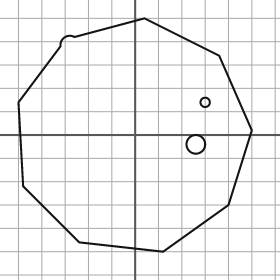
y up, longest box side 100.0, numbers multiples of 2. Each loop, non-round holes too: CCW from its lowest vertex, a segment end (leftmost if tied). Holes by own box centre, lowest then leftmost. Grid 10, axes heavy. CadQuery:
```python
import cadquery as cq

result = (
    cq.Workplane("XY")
    .moveTo(12.0, -50.0)
    .lineTo(40.0, -30.0)
    .lineTo(50.0, 2.0)
    .lineTo(36.0, 34.0)
    .lineTo(4.0, 50.0)
    .lineTo(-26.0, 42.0)
    .threePointArc((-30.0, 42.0), (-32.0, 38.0))
    .lineTo(-50.0, 14.0)
    .lineTo(-48.0, -22.0)
    .lineTo(-24.0, -46.0)
    .close()
    .moveTo(26.0, -4.0)
    .circle(4.0)
    .moveTo(30.0, 14.0)
    .circle(2.0)
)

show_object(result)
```